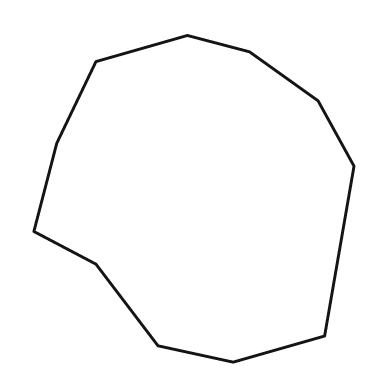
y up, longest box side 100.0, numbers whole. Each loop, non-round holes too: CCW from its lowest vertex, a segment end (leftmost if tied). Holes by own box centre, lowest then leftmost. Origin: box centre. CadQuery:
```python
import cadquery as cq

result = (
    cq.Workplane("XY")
    .moveTo(12.0, -50.0)
    .lineTo(40.0, -42.0)
    .lineTo(49.0, 10.0)
    .lineTo(38.0, 30.0)
    .lineTo(17.0, 45.0)
    .lineTo(-2.0, 50.0)
    .lineTo(-30.0, 42.0)
    .lineTo(-42.0, 17.0)
    .lineTo(-49.0, -10.0)
    .lineTo(-30.0, -20.0)
    .lineTo(-11.0, -45.0)
    .close()
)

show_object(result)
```